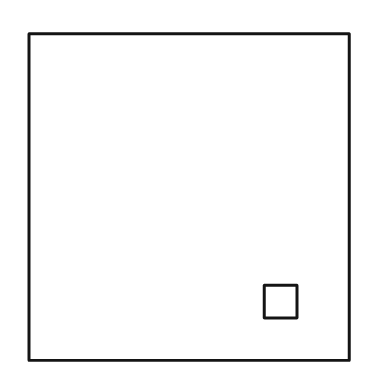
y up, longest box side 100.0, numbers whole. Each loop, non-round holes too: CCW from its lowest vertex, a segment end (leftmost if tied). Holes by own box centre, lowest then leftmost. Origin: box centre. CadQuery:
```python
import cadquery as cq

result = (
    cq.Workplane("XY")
    .moveTo(-49.0, -50.0)
    .lineTo(49.0, -50.0)
    .lineTo(49.0, 50.0)
    .lineTo(-49.0, 50.0)
    .close()
    .moveTo(23.0, -37.0)
    .lineTo(33.0, -37.0)
    .lineTo(33.0, -27.0)
    .lineTo(23.0, -27.0)
    .close()
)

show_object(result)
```